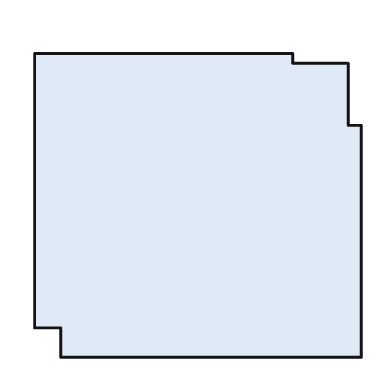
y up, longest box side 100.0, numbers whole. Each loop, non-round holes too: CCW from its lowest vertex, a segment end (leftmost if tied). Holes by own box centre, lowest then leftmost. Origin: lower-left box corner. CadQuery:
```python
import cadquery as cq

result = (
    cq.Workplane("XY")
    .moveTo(8.0, 0.0)
    .lineTo(100.0, 0.0)
    .lineTo(100.0, 71.0)
    .lineTo(96.0, 71.0)
    .lineTo(96.0, 90.0)
    .lineTo(79.0, 90.0)
    .lineTo(79.0, 93.0)
    .lineTo(0.0, 93.0)
    .lineTo(0.0, 9.0)
    .lineTo(8.0, 9.0)
    .close()
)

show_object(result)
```